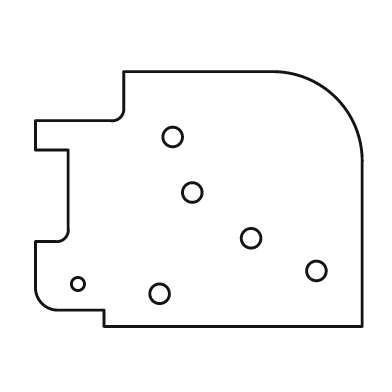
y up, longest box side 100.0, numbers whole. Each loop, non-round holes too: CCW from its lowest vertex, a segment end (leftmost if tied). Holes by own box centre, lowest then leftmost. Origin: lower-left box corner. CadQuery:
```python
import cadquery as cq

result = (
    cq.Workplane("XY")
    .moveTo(21.0, 0.0)
    .lineTo(100.0, 0.0)
    .lineTo(100.0, 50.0)
    .threePointArc((92.0, 70.0), (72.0, 78.0))
    .lineTo(27.0, 78.0)
    .lineTo(27.0, 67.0)
    .threePointArc((26.0, 64.0), (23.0, 63.0))
    .lineTo(0.0, 63.0)
    .lineTo(0.0, 54.0)
    .lineTo(10.0, 54.0)
    .lineTo(10.0, 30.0)
    .threePointArc((9.0, 27.0), (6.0, 26.0))
    .lineTo(0.0, 26.0)
    .lineTo(0.0, 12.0)
    .threePointArc((2.0, 7.0), (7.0, 5.0))
    .lineTo(21.0, 5.0)
    .close()
    .moveTo(38.0, 10.0)
    .circle(3.0)
    .moveTo(13.0, 13.0)
    .circle(2.0)
    .moveTo(86.0, 17.0)
    .circle(3.0)
    .moveTo(66.0, 27.0)
    .circle(3.0)
    .moveTo(48.0, 41.0)
    .circle(3.0)
    .moveTo(42.0, 58.0)
    .circle(3.0)
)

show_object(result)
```